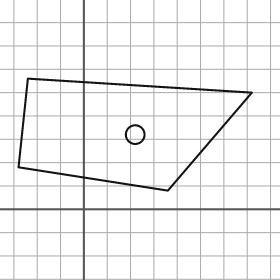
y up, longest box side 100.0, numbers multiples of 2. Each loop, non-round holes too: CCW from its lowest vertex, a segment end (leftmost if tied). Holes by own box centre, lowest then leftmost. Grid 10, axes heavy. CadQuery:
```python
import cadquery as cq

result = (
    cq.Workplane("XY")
    .moveTo(36.0, 8.0)
    .lineTo(72.0, 50.0)
    .lineTo(-24.0, 56.0)
    .lineTo(-28.0, 18.0)
    .close()
    .moveTo(22.0, 32.0)
    .circle(4.0)
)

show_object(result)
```